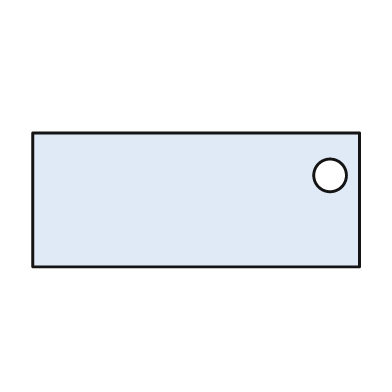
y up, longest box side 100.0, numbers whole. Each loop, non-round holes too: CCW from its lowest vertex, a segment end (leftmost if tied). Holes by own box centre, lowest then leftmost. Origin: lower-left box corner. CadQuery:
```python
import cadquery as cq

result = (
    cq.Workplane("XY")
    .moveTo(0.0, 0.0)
    .lineTo(100.0, 0.0)
    .lineTo(100.0, 41.0)
    .lineTo(0.0, 41.0)
    .close()
    .moveTo(91.0, 28.0)
    .circle(5.0)
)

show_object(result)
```